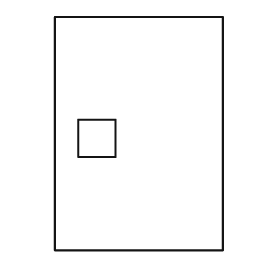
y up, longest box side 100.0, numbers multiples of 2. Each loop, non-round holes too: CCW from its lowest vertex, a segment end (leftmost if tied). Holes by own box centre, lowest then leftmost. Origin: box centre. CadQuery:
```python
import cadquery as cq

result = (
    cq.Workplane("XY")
    .moveTo(-36.0, -50.0)
    .lineTo(36.0, -50.0)
    .lineTo(36.0, 50.0)
    .lineTo(-36.0, 50.0)
    .close()
    .moveTo(-26.0, -10.0)
    .lineTo(-10.0, -10.0)
    .lineTo(-10.0, 6.0)
    .lineTo(-26.0, 6.0)
    .close()
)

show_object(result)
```